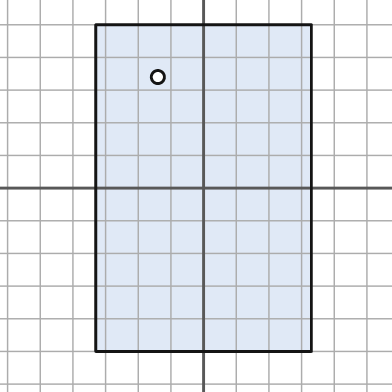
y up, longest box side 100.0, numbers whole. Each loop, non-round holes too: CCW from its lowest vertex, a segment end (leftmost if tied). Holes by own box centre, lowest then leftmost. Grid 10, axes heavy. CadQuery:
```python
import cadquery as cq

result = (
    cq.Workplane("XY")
    .moveTo(-33.0, -50.0)
    .lineTo(33.0, -50.0)
    .lineTo(33.0, 50.0)
    .lineTo(-33.0, 50.0)
    .close()
    .moveTo(-14.0, 34.0)
    .circle(2.0)
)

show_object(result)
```